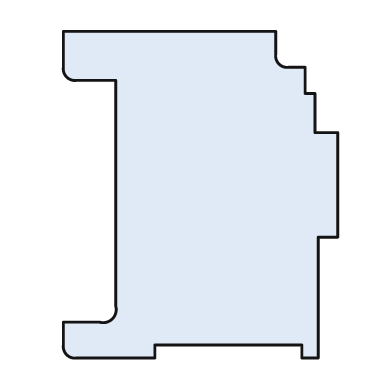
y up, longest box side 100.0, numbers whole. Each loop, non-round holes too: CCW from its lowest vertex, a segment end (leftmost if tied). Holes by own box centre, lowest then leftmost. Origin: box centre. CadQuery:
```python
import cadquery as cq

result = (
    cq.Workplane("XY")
    .moveTo(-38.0, -50.0)
    .lineTo(-14.0, -50.0)
    .lineTo(-14.0, -46.0)
    .lineTo(31.0, -46.0)
    .lineTo(31.0, -50.0)
    .lineTo(36.0, -50.0)
    .lineTo(36.0, -13.0)
    .lineTo(42.0, -13.0)
    .lineTo(42.0, 19.0)
    .lineTo(35.0, 19.0)
    .lineTo(35.0, 31.0)
    .lineTo(32.0, 31.0)
    .lineTo(32.0, 39.0)
    .lineTo(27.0, 39.0)
    .threePointArc((24.0, 40.0), (23.0, 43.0))
    .lineTo(23.0, 50.0)
    .lineTo(-42.0, 50.0)
    .lineTo(-42.0, 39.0)
    .threePointArc((-41.0, 36.0), (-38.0, 35.0))
    .lineTo(-26.0, 35.0)
    .lineTo(-26.0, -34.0)
    .threePointArc((-27.0, -38.0), (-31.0, -39.0))
    .lineTo(-42.0, -39.0)
    .lineTo(-42.0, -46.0)
    .threePointArc((-41.0, -49.0), (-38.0, -50.0))
    .close()
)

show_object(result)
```